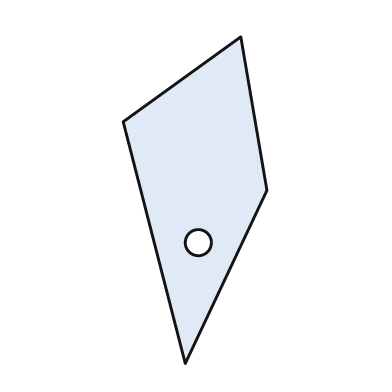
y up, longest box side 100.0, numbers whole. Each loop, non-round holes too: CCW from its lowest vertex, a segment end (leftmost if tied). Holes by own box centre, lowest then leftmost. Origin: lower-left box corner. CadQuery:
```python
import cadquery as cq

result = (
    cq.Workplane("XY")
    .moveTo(19.0, 0.0)
    .lineTo(44.0, 53.0)
    .lineTo(36.0, 100.0)
    .lineTo(0.0, 74.0)
    .close()
    .moveTo(23.0, 37.0)
    .circle(4.0)
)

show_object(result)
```